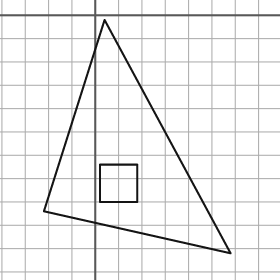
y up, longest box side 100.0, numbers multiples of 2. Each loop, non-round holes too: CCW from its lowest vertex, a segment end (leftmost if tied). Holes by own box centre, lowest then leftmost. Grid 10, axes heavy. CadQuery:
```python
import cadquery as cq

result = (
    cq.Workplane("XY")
    .moveTo(58.0, -102.0)
    .lineTo(4.0, -2.0)
    .lineTo(-22.0, -84.0)
    .close()
    .moveTo(2.0, -80.0)
    .lineTo(18.0, -80.0)
    .lineTo(18.0, -64.0)
    .lineTo(2.0, -64.0)
    .close()
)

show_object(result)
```